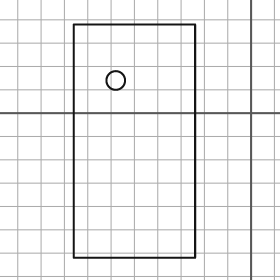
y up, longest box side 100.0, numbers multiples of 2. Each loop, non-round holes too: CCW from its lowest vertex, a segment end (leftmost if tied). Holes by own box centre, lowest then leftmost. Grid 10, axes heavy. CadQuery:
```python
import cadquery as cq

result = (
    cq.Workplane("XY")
    .moveTo(-76.0, -62.0)
    .lineTo(-24.0, -62.0)
    .lineTo(-24.0, 38.0)
    .lineTo(-76.0, 38.0)
    .close()
    .moveTo(-58.0, 14.0)
    .circle(4.0)
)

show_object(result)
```